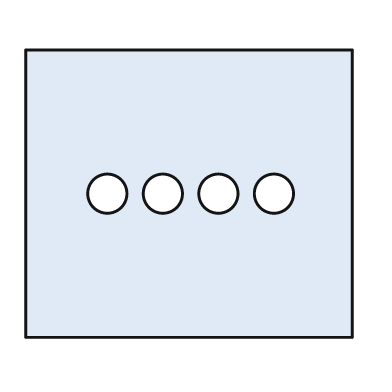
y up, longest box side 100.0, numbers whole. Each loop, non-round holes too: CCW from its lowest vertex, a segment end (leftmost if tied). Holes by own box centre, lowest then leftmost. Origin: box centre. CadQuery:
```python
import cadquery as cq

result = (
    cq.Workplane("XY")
    .moveTo(-50.0, -44.0)
    .lineTo(50.0, -44.0)
    .lineTo(50.0, 44.0)
    .lineTo(-50.0, 44.0)
    .close()
    .moveTo(-25.0, 0.0)
    .circle(6.0)
    .moveTo(-8.0, 0.0)
    .circle(6.0)
    .moveTo(9.0, 0.0)
    .circle(6.0)
    .moveTo(26.0, 0.0)
    .circle(6.0)
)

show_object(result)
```